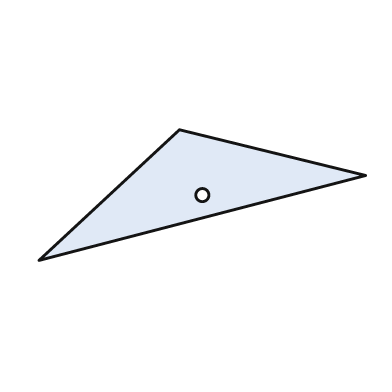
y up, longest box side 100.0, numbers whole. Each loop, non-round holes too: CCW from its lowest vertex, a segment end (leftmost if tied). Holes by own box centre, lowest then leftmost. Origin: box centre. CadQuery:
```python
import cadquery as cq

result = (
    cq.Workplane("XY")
    .moveTo(-50.0, -20.0)
    .lineTo(50.0, 6.0)
    .lineTo(-7.0, 20.0)
    .close()
    .moveTo(0.0, 0.0)
    .circle(2.0)
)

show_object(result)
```